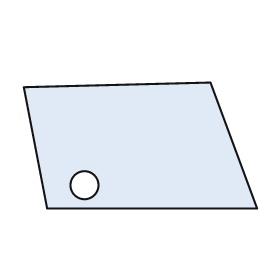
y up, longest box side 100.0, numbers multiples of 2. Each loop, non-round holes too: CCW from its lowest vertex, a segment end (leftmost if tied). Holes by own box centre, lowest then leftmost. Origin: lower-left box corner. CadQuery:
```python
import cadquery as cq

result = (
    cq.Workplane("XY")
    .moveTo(10.0, 0.0)
    .lineTo(100.0, 0.0)
    .lineTo(80.0, 54.0)
    .lineTo(0.0, 52.0)
    .close()
    .moveTo(26.0, 10.0)
    .circle(6.0)
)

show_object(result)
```